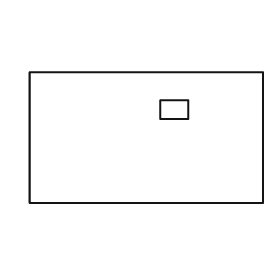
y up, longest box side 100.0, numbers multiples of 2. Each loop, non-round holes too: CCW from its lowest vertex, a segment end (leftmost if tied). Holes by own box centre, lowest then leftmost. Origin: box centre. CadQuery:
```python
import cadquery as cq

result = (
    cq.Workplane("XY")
    .moveTo(-50.0, -28.0)
    .lineTo(50.0, -28.0)
    .lineTo(50.0, 28.0)
    .lineTo(-50.0, 28.0)
    .close()
    .moveTo(6.0, 8.0)
    .lineTo(18.0, 8.0)
    .lineTo(18.0, 16.0)
    .lineTo(6.0, 16.0)
    .close()
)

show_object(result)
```